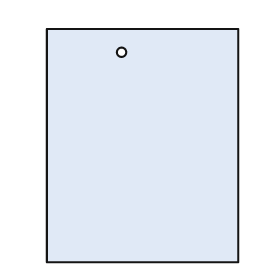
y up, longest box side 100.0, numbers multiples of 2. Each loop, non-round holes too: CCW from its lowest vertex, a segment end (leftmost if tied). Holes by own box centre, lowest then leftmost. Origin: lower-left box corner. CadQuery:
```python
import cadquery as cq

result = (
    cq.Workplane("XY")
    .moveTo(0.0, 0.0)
    .lineTo(82.0, 0.0)
    .lineTo(82.0, 100.0)
    .lineTo(0.0, 100.0)
    .close()
    .moveTo(32.0, 90.0)
    .circle(2.0)
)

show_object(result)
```